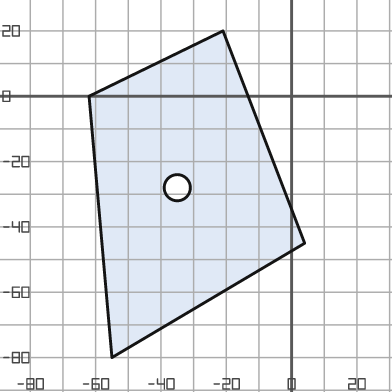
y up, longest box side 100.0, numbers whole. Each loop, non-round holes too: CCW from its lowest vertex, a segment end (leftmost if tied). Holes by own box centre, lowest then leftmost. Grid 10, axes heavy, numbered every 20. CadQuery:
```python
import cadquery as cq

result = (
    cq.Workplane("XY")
    .moveTo(-55.0, -80.0)
    .lineTo(4.0, -45.0)
    .lineTo(-21.0, 20.0)
    .lineTo(-62.0, 0.0)
    .close()
    .moveTo(-35.0, -28.0)
    .circle(4.0)
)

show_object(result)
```